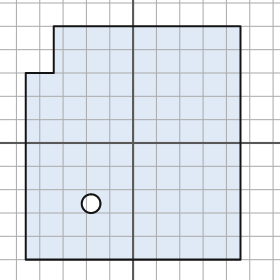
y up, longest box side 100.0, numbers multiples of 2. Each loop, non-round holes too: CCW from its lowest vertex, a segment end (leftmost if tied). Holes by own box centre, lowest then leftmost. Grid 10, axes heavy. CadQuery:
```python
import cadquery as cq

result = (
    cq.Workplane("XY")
    .moveTo(-46.0, -50.0)
    .lineTo(46.0, -50.0)
    .lineTo(46.0, 50.0)
    .lineTo(-34.0, 50.0)
    .lineTo(-34.0, 30.0)
    .lineTo(-46.0, 30.0)
    .close()
    .moveTo(-18.0, -26.0)
    .circle(4.0)
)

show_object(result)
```